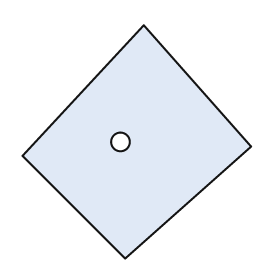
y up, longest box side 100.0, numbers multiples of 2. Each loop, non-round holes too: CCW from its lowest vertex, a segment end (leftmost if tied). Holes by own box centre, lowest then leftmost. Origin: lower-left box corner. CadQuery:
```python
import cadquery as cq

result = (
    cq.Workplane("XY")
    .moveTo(44.0, 0.0)
    .lineTo(98.0, 48.0)
    .lineTo(52.0, 100.0)
    .lineTo(0.0, 44.0)
    .close()
    .moveTo(42.0, 50.0)
    .circle(4.0)
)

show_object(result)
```